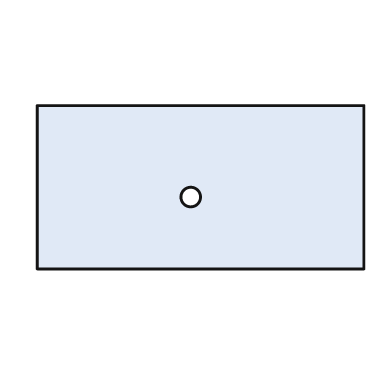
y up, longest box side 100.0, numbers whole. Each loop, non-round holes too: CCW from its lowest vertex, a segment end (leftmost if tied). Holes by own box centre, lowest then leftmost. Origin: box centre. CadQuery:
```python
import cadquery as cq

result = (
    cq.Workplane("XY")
    .moveTo(-50.0, -25.0)
    .lineTo(50.0, -25.0)
    .lineTo(50.0, 25.0)
    .lineTo(-50.0, 25.0)
    .close()
    .moveTo(-3.0, -3.0)
    .circle(3.0)
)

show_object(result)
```